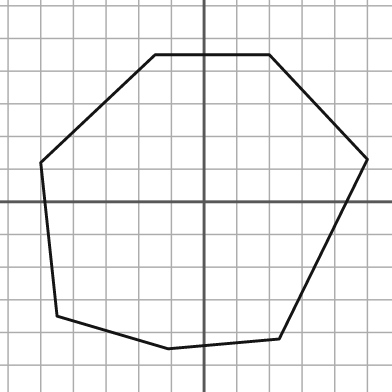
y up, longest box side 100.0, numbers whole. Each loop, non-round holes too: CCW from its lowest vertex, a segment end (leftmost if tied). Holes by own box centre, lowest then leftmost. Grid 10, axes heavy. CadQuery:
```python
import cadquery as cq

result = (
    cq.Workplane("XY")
    .moveTo(-11.0, -45.0)
    .lineTo(23.0, -42.0)
    .lineTo(50.0, 13.0)
    .lineTo(20.0, 45.0)
    .lineTo(-15.0, 45.0)
    .lineTo(-50.0, 12.0)
    .lineTo(-45.0, -35.0)
    .close()
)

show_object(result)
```